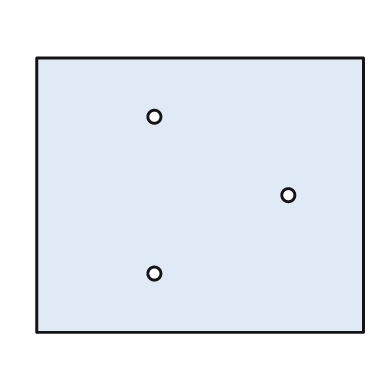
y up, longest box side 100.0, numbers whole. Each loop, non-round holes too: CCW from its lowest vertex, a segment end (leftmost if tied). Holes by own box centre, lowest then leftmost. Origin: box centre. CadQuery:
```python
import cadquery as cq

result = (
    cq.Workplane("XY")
    .moveTo(-50.0, -42.0)
    .lineTo(50.0, -42.0)
    .lineTo(50.0, 42.0)
    .lineTo(-50.0, 42.0)
    .close()
    .moveTo(-14.0, -24.0)
    .circle(2.0)
    .moveTo(27.0, 0.0)
    .circle(2.0)
    .moveTo(-14.0, 24.0)
    .circle(2.0)
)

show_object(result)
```